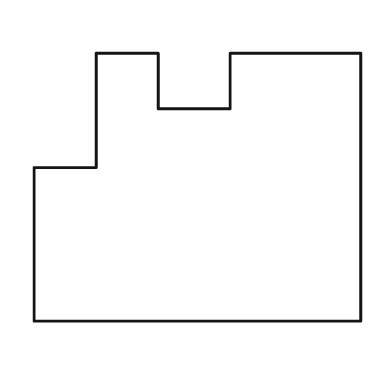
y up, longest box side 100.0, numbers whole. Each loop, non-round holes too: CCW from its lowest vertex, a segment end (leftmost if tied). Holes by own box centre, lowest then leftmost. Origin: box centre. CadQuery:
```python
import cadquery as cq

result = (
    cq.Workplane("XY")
    .moveTo(-50.0, -41.0)
    .lineTo(50.0, -41.0)
    .lineTo(50.0, 41.0)
    .lineTo(10.0, 41.0)
    .lineTo(10.0, 24.0)
    .lineTo(-12.0, 24.0)
    .lineTo(-12.0, 41.0)
    .lineTo(-31.0, 41.0)
    .lineTo(-31.0, 6.0)
    .lineTo(-50.0, 6.0)
    .close()
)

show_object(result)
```